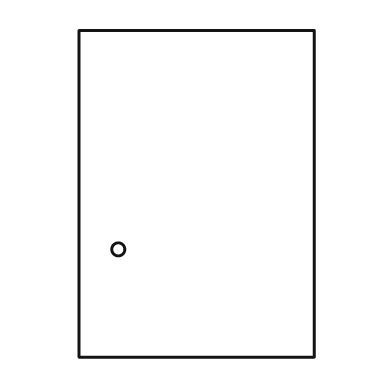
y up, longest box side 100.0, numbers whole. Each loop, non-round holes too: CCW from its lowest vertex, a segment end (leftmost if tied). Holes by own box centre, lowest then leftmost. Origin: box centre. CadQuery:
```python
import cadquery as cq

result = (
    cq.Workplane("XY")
    .moveTo(-36.0, -50.0)
    .lineTo(36.0, -50.0)
    .lineTo(36.0, 50.0)
    .lineTo(-36.0, 50.0)
    .close()
    .moveTo(-24.0, -17.0)
    .circle(2.0)
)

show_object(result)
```